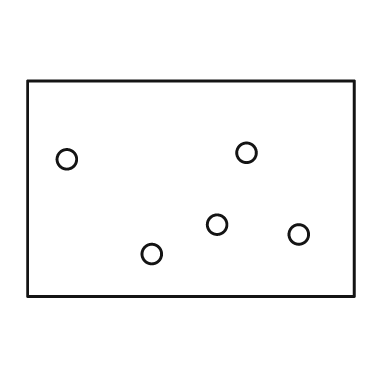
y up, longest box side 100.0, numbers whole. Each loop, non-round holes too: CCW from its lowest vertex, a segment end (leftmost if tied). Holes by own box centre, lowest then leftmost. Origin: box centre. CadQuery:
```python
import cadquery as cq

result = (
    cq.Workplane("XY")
    .moveTo(-50.0, -33.0)
    .lineTo(50.0, -33.0)
    .lineTo(50.0, 33.0)
    .lineTo(-50.0, 33.0)
    .close()
    .moveTo(-12.0, -20.0)
    .circle(3.0)
    .moveTo(33.0, -14.0)
    .circle(3.0)
    .moveTo(8.0, -11.0)
    .circle(3.0)
    .moveTo(-38.0, 9.0)
    .circle(3.0)
    .moveTo(17.0, 11.0)
    .circle(3.0)
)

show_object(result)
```